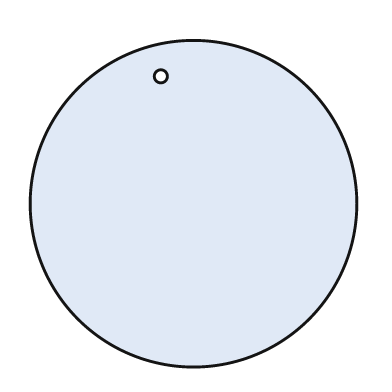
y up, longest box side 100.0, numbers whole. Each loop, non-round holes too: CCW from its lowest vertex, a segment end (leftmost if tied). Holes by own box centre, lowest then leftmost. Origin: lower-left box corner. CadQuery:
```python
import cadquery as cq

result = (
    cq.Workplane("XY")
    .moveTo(50.0, 50.0)
    .circle(50.0)
    .moveTo(40.0, 89.0)
    .circle(2.0)
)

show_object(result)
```